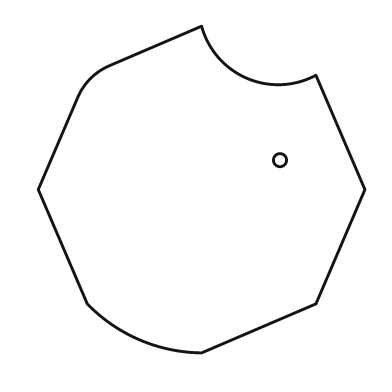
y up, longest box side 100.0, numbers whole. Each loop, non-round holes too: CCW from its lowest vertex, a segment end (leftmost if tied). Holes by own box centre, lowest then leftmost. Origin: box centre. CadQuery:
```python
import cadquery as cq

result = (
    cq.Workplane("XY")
    .moveTo(0.0, -50.0)
    .lineTo(35.0, -35.0)
    .lineTo(50.0, 0.0)
    .lineTo(35.0, 35.0)
    .threePointArc((14.0, 34.0), (0.0, 50.0))
    .lineTo(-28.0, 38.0)
    .threePointArc((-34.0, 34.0), (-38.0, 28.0))
    .lineTo(-50.0, 0.0)
    .lineTo(-35.0, -35.0)
    .threePointArc((-19.0, -46.0), (0.0, -50.0))
    .close()
    .moveTo(24.0, 9.0)
    .circle(2.0)
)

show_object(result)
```